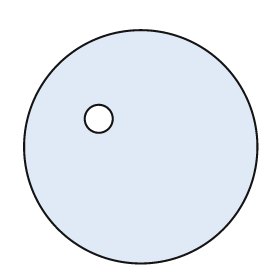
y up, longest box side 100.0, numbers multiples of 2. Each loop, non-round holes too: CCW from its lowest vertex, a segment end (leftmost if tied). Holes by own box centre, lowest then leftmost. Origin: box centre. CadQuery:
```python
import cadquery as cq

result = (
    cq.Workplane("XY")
    .moveTo(0.0, 0.0)
    .circle(50.0)
    .moveTo(-18.0, 12.0)
    .circle(6.0)
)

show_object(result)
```